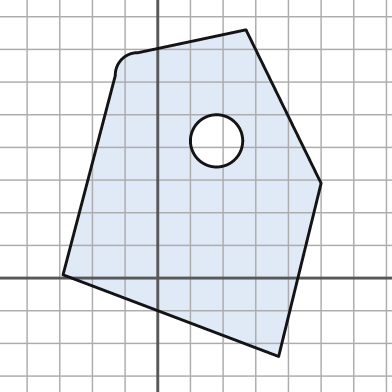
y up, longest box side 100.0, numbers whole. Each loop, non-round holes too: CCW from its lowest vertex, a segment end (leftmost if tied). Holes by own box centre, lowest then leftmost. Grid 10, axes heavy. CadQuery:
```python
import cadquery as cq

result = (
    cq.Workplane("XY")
    .moveTo(37.0, -24.0)
    .lineTo(50.0, 29.0)
    .lineTo(27.0, 76.0)
    .lineTo(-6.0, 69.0)
    .threePointArc((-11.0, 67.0), (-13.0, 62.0))
    .lineTo(-29.0, 1.0)
    .close()
    .moveTo(18.0, 42.0)
    .circle(8.0)
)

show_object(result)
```